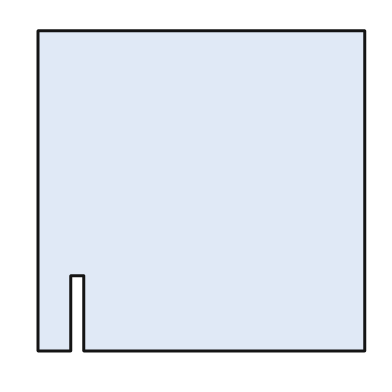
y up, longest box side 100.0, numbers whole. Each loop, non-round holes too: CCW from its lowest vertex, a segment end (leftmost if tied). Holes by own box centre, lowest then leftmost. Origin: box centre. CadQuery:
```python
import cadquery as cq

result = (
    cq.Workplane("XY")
    .moveTo(-50.0, -49.0)
    .lineTo(-40.0, -49.0)
    .lineTo(-40.0, -26.0)
    .lineTo(-36.0, -26.0)
    .lineTo(-36.0, -49.0)
    .lineTo(50.0, -49.0)
    .lineTo(50.0, 49.0)
    .lineTo(-50.0, 49.0)
    .close()
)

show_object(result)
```